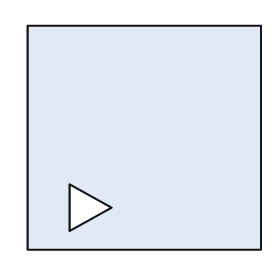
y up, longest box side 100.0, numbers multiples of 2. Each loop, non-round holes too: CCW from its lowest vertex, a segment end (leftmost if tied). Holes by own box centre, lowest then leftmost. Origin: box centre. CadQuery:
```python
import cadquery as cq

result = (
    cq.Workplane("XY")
    .moveTo(-50.0, -48.0)
    .lineTo(50.0, -48.0)
    .lineTo(50.0, 48.0)
    .lineTo(-50.0, 48.0)
    .close()
    .moveTo(-32.0, -40.0)
    .lineTo(-14.0, -30.0)
    .lineTo(-32.0, -20.0)
    .close()
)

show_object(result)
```